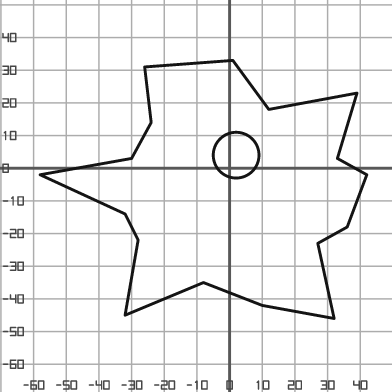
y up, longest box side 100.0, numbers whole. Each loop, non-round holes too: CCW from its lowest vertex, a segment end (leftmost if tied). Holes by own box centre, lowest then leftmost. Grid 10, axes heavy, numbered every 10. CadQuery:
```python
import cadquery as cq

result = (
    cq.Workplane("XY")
    .moveTo(32.0, -46.0)
    .lineTo(27.0, -23.0)
    .lineTo(36.0, -18.0)
    .lineTo(42.0, -2.0)
    .lineTo(33.0, 3.0)
    .lineTo(39.0, 23.0)
    .lineTo(12.0, 18.0)
    .lineTo(1.0, 33.0)
    .lineTo(-26.0, 31.0)
    .lineTo(-24.0, 14.0)
    .lineTo(-30.0, 3.0)
    .lineTo(-58.0, -2.0)
    .lineTo(-32.0, -14.0)
    .lineTo(-28.0, -22.0)
    .lineTo(-32.0, -45.0)
    .lineTo(-8.0, -35.0)
    .lineTo(10.0, -42.0)
    .close()
    .moveTo(2.0, 4.0)
    .circle(7.0)
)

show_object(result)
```